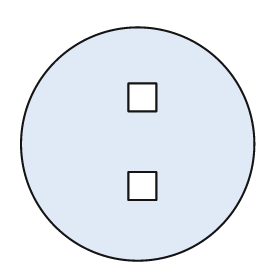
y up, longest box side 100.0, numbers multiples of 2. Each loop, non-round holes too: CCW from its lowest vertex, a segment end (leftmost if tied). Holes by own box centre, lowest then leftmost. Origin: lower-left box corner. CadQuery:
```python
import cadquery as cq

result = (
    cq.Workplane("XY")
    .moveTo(50.0, 50.0)
    .circle(50.0)
    .moveTo(46.0, 26.0)
    .lineTo(58.0, 26.0)
    .lineTo(58.0, 38.0)
    .lineTo(46.0, 38.0)
    .close()
    .moveTo(46.0, 64.0)
    .lineTo(58.0, 64.0)
    .lineTo(58.0, 76.0)
    .lineTo(46.0, 76.0)
    .close()
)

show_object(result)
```